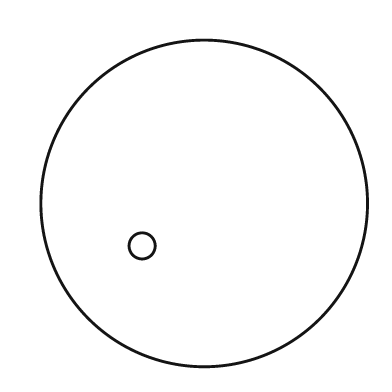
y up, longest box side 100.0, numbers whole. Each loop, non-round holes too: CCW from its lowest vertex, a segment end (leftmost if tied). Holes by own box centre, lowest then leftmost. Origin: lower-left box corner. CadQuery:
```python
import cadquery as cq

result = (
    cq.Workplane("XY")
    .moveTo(50.0, 50.0)
    .circle(50.0)
    .moveTo(31.0, 37.0)
    .circle(4.0)
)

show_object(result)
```